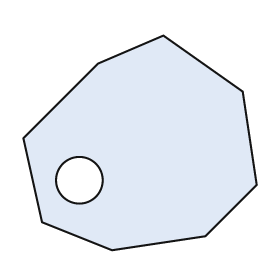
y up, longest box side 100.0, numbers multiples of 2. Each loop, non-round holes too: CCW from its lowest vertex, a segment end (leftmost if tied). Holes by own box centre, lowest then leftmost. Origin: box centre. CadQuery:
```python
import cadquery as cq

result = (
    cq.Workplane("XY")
    .moveTo(-12.0, -46.0)
    .lineTo(28.0, -40.0)
    .lineTo(50.0, -18.0)
    .lineTo(44.0, 22.0)
    .lineTo(10.0, 46.0)
    .lineTo(-18.0, 34.0)
    .lineTo(-50.0, 2.0)
    .lineTo(-42.0, -34.0)
    .close()
    .moveTo(-26.0, -16.0)
    .circle(10.0)
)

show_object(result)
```